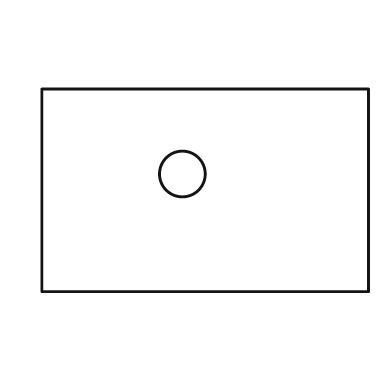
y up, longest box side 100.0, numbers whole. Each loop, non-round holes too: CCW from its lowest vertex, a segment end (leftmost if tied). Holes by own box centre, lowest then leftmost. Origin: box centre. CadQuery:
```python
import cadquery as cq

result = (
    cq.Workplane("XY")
    .moveTo(-50.0, -31.0)
    .lineTo(50.0, -31.0)
    .lineTo(50.0, 31.0)
    .lineTo(-50.0, 31.0)
    .close()
    .moveTo(-7.0, 5.0)
    .circle(7.0)
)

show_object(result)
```